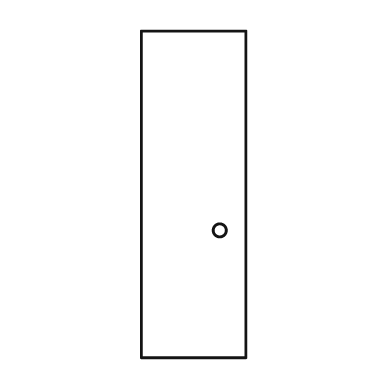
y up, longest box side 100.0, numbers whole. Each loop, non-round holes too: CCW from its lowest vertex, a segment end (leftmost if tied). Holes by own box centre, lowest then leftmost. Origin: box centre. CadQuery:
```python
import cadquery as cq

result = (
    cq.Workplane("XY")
    .moveTo(-16.0, -50.0)
    .lineTo(16.0, -50.0)
    .lineTo(16.0, 50.0)
    .lineTo(-16.0, 50.0)
    .close()
    .moveTo(8.0, -11.0)
    .circle(2.0)
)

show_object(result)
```